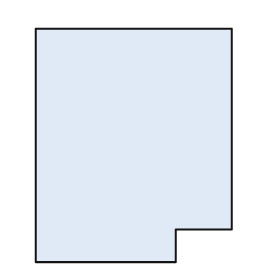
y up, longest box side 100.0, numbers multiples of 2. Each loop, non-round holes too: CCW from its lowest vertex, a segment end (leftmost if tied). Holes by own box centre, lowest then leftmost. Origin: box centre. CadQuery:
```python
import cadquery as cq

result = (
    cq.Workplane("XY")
    .moveTo(-42.0, -50.0)
    .lineTo(18.0, -50.0)
    .lineTo(18.0, -36.0)
    .lineTo(42.0, -36.0)
    .lineTo(42.0, 50.0)
    .lineTo(-42.0, 50.0)
    .close()
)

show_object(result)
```